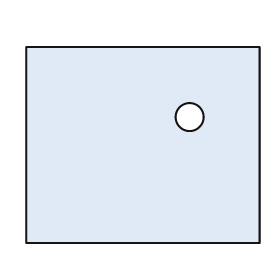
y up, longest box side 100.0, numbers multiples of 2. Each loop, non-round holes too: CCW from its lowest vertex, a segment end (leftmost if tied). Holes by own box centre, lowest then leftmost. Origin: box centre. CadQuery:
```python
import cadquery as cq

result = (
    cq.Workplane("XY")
    .moveTo(-50.0, -42.0)
    .lineTo(50.0, -42.0)
    .lineTo(50.0, 42.0)
    .lineTo(-50.0, 42.0)
    .close()
    .moveTo(20.0, 12.0)
    .circle(6.0)
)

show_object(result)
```